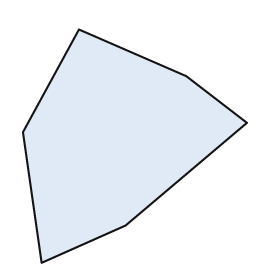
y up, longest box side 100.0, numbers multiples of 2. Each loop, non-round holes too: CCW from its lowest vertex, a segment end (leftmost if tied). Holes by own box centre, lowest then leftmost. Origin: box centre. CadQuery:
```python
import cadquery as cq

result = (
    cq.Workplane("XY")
    .moveTo(-40.0, -50.0)
    .lineTo(-4.0, -34.0)
    .lineTo(48.0, 10.0)
    .lineTo(22.0, 30.0)
    .lineTo(-24.0, 50.0)
    .lineTo(-48.0, 6.0)
    .close()
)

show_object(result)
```